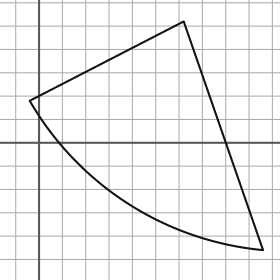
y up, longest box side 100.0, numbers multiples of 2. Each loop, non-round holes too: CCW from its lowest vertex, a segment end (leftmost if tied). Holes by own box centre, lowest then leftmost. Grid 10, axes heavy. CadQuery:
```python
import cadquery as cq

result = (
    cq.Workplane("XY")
    .moveTo(96.0, -46.0)
    .lineTo(62.0, 52.0)
    .lineTo(-4.0, 18.0)
    .threePointArc((38.0, -26.0), (96.0, -46.0))
    .close()
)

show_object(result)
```